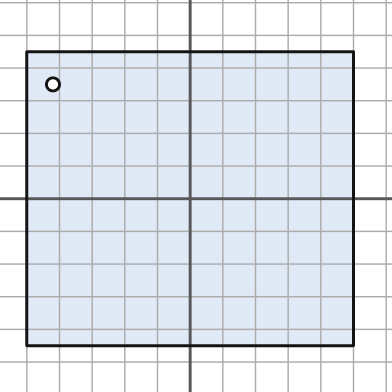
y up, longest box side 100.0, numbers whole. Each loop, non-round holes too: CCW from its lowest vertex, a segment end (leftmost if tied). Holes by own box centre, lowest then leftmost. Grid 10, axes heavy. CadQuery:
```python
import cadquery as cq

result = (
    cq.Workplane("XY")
    .moveTo(-50.0, -45.0)
    .lineTo(50.0, -45.0)
    .lineTo(50.0, 45.0)
    .lineTo(-50.0, 45.0)
    .close()
    .moveTo(-42.0, 35.0)
    .circle(2.0)
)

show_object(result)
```